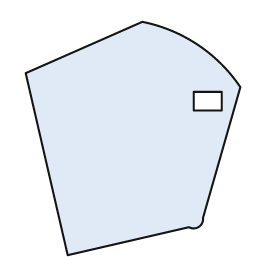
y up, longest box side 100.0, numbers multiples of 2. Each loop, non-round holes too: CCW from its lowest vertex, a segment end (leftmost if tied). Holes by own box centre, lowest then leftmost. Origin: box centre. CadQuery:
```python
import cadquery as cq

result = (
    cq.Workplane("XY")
    .moveTo(-28.0, -50.0)
    .lineTo(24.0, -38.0)
    .threePointArc((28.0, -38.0), (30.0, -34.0))
    .lineTo(46.0, 22.0)
    .threePointArc((28.0, 40.0), (4.0, 50.0))
    .lineTo(-46.0, 28.0)
    .close()
    .moveTo(26.0, 12.0)
    .lineTo(38.0, 12.0)
    .lineTo(38.0, 20.0)
    .lineTo(26.0, 20.0)
    .close()
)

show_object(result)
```